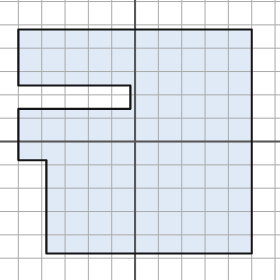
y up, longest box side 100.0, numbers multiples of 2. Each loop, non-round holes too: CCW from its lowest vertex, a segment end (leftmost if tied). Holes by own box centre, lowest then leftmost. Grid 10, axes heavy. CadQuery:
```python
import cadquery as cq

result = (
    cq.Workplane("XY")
    .moveTo(-38.0, -48.0)
    .lineTo(50.0, -48.0)
    .lineTo(50.0, 48.0)
    .lineTo(-50.0, 48.0)
    .lineTo(-50.0, 24.0)
    .lineTo(-2.0, 24.0)
    .lineTo(-2.0, 14.0)
    .lineTo(-50.0, 14.0)
    .lineTo(-50.0, -8.0)
    .lineTo(-38.0, -8.0)
    .close()
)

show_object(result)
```